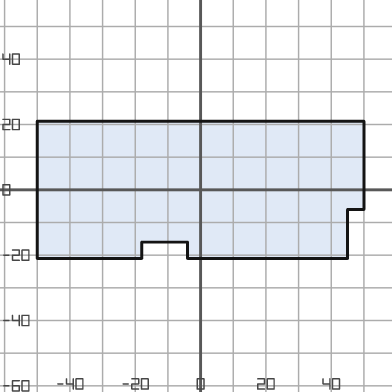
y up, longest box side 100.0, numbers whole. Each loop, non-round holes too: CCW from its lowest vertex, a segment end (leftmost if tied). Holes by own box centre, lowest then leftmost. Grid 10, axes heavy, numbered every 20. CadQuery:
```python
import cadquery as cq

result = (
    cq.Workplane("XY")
    .moveTo(-50.0, -21.0)
    .lineTo(-18.0, -21.0)
    .lineTo(-18.0, -16.0)
    .lineTo(-4.0, -16.0)
    .lineTo(-4.0, -21.0)
    .lineTo(45.0, -21.0)
    .lineTo(45.0, -6.0)
    .lineTo(50.0, -6.0)
    .lineTo(50.0, 21.0)
    .lineTo(-50.0, 21.0)
    .close()
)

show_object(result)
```